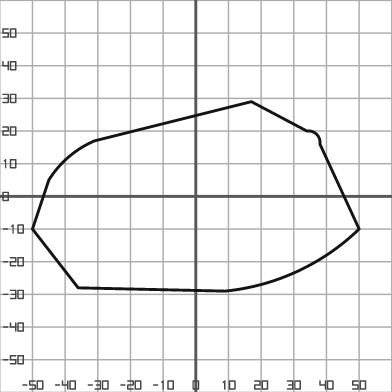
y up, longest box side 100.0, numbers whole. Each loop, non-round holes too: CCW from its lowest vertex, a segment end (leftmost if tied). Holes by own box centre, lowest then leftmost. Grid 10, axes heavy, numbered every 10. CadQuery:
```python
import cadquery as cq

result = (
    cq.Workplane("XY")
    .moveTo(9.0, -29.0)
    .threePointArc((31.0, -23.0), (50.0, -10.0))
    .lineTo(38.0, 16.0)
    .threePointArc((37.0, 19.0), (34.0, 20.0))
    .lineTo(17.0, 29.0)
    .lineTo(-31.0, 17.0)
    .threePointArc((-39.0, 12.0), (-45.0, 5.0))
    .lineTo(-50.0, -10.0)
    .lineTo(-36.0, -28.0)
    .close()
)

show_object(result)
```